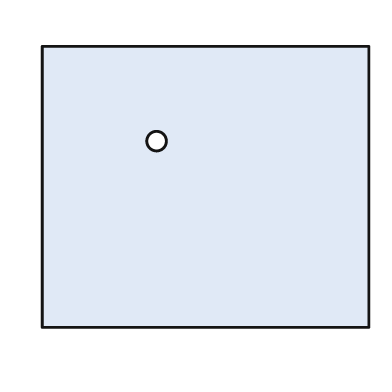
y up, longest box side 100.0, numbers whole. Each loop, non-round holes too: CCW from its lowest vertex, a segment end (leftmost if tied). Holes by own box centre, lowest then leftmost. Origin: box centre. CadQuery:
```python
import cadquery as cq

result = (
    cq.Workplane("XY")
    .moveTo(-50.0, -43.0)
    .lineTo(50.0, -43.0)
    .lineTo(50.0, 43.0)
    .lineTo(-50.0, 43.0)
    .close()
    .moveTo(-15.0, 14.0)
    .circle(3.0)
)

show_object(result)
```